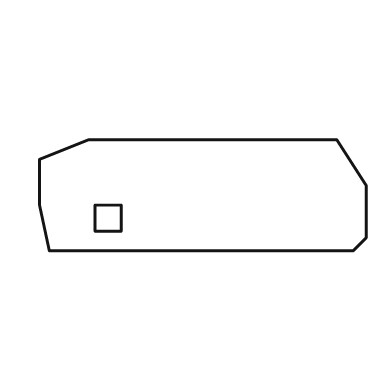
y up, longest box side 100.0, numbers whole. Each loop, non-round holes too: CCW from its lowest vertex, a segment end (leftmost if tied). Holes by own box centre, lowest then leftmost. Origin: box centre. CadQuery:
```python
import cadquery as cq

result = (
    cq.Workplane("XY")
    .moveTo(-47.0, -17.0)
    .lineTo(46.0, -17.0)
    .lineTo(50.0, -13.0)
    .lineTo(50.0, 3.0)
    .lineTo(41.0, 17.0)
    .lineTo(-35.0, 17.0)
    .lineTo(-50.0, 11.0)
    .lineTo(-50.0, -3.0)
    .close()
    .moveTo(-33.0, -11.0)
    .lineTo(-25.0, -11.0)
    .lineTo(-25.0, -3.0)
    .lineTo(-33.0, -3.0)
    .close()
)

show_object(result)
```